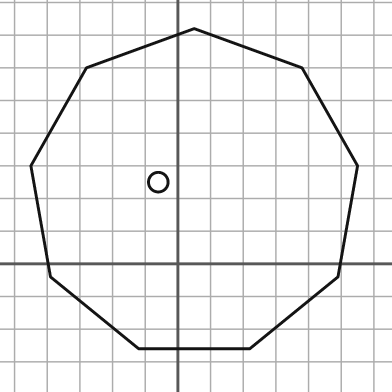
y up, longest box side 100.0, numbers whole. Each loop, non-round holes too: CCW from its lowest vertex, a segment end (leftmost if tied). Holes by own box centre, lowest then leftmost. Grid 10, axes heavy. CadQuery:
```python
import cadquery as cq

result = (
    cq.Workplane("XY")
    .moveTo(-12.0, -26.0)
    .lineTo(22.0, -26.0)
    .lineTo(49.0, -4.0)
    .lineTo(55.0, 30.0)
    .lineTo(38.0, 60.0)
    .lineTo(5.0, 72.0)
    .lineTo(-28.0, 60.0)
    .lineTo(-45.0, 30.0)
    .lineTo(-39.0, -4.0)
    .close()
    .moveTo(-6.0, 25.0)
    .circle(3.0)
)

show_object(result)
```